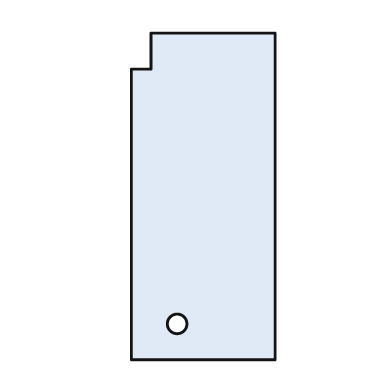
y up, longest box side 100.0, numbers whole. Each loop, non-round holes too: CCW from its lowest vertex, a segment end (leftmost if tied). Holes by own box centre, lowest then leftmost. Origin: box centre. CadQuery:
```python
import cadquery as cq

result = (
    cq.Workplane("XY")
    .moveTo(-22.0, -50.0)
    .lineTo(22.0, -50.0)
    .lineTo(22.0, 50.0)
    .lineTo(-16.0, 50.0)
    .lineTo(-16.0, 39.0)
    .lineTo(-22.0, 39.0)
    .close()
    .moveTo(-8.0, -39.0)
    .circle(3.0)
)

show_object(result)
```